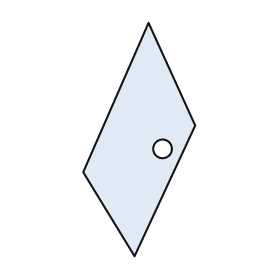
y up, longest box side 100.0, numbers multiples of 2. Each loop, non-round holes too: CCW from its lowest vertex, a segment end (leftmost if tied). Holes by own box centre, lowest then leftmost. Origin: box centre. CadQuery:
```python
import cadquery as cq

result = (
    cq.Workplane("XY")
    .moveTo(-2.0, -50.0)
    .lineTo(24.0, 6.0)
    .lineTo(4.0, 50.0)
    .lineTo(-24.0, -14.0)
    .close()
    .moveTo(10.0, -4.0)
    .circle(4.0)
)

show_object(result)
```